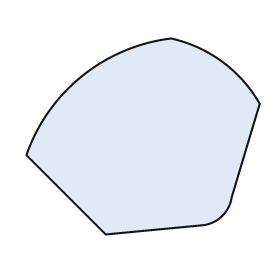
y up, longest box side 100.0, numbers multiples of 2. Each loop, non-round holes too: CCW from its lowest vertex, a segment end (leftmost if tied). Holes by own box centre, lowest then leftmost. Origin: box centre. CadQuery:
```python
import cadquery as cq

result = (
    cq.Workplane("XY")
    .moveTo(-16.0, -42.0)
    .lineTo(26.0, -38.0)
    .threePointArc((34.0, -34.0), (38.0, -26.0))
    .lineTo(50.0, 14.0)
    .threePointArc((34.0, 32.0), (12.0, 42.0))
    .threePointArc((-26.0, 26.0), (-50.0, -8.0))
    .close()
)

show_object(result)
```